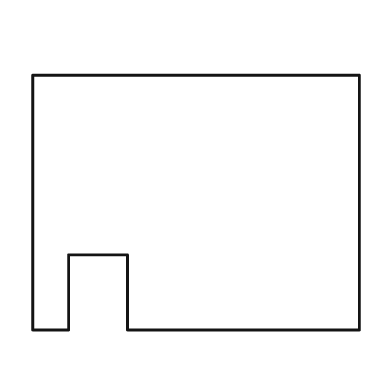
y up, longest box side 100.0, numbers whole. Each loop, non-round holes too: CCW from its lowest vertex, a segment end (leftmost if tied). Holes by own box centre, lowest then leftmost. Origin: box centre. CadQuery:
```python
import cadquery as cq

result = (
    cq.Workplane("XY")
    .moveTo(-50.0, -39.0)
    .lineTo(-39.0, -39.0)
    .lineTo(-39.0, -16.0)
    .lineTo(-21.0, -16.0)
    .lineTo(-21.0, -39.0)
    .lineTo(50.0, -39.0)
    .lineTo(50.0, 39.0)
    .lineTo(-50.0, 39.0)
    .close()
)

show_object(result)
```